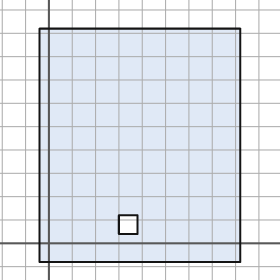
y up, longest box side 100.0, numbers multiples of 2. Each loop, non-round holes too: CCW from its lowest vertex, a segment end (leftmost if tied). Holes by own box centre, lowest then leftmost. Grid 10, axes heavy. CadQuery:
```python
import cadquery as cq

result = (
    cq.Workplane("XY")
    .moveTo(-4.0, -8.0)
    .lineTo(82.0, -8.0)
    .lineTo(82.0, 92.0)
    .lineTo(-4.0, 92.0)
    .close()
    .moveTo(30.0, 4.0)
    .lineTo(38.0, 4.0)
    .lineTo(38.0, 12.0)
    .lineTo(30.0, 12.0)
    .close()
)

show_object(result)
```